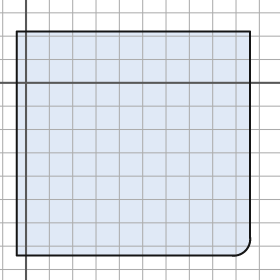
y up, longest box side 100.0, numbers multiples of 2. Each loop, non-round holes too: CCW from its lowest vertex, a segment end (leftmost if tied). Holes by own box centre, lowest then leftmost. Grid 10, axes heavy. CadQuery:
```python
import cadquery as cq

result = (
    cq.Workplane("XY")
    .moveTo(-4.0, -74.0)
    .lineTo(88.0, -74.0)
    .threePointArc((94.0, -72.0), (96.0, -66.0))
    .lineTo(96.0, 22.0)
    .lineTo(-4.0, 22.0)
    .close()
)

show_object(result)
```